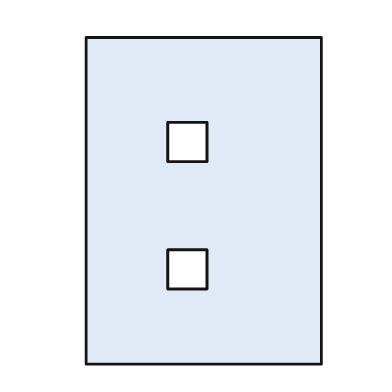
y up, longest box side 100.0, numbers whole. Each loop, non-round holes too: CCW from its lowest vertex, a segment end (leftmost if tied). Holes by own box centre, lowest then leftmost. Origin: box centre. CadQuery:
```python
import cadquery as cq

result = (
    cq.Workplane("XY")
    .moveTo(-36.0, -50.0)
    .lineTo(36.0, -50.0)
    .lineTo(36.0, 50.0)
    .lineTo(-36.0, 50.0)
    .close()
    .moveTo(-11.0, -27.0)
    .lineTo(1.0, -27.0)
    .lineTo(1.0, -15.0)
    .lineTo(-11.0, -15.0)
    .close()
    .moveTo(-11.0, 12.0)
    .lineTo(1.0, 12.0)
    .lineTo(1.0, 24.0)
    .lineTo(-11.0, 24.0)
    .close()
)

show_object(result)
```